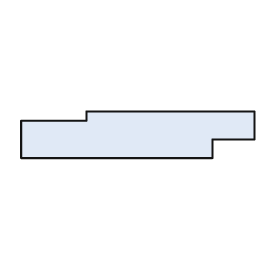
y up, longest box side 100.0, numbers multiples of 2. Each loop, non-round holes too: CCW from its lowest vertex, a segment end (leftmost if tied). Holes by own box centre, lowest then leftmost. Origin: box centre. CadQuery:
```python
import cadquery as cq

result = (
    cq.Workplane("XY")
    .moveTo(-50.0, -10.0)
    .lineTo(32.0, -10.0)
    .lineTo(32.0, -2.0)
    .lineTo(50.0, -2.0)
    .lineTo(50.0, 10.0)
    .lineTo(-22.0, 10.0)
    .lineTo(-22.0, 6.0)
    .lineTo(-50.0, 6.0)
    .close()
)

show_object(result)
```